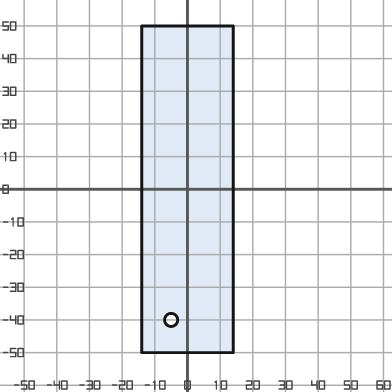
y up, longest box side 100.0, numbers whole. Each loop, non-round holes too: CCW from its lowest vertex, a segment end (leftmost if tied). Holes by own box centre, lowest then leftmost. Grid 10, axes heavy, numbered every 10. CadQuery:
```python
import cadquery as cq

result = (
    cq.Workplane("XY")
    .moveTo(-14.0, -50.0)
    .lineTo(14.0, -50.0)
    .lineTo(14.0, 50.0)
    .lineTo(-14.0, 50.0)
    .close()
    .moveTo(-5.0, -40.0)
    .circle(2.0)
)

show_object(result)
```